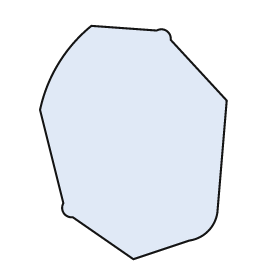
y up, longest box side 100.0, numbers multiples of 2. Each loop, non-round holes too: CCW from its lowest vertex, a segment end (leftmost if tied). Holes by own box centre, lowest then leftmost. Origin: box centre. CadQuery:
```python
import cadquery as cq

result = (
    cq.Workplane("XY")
    .moveTo(0.0, -50.0)
    .lineTo(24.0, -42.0)
    .threePointArc((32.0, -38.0), (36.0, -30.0))
    .lineTo(40.0, 18.0)
    .lineTo(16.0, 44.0)
    .threePointArc((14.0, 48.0), (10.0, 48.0))
    .lineTo(-18.0, 50.0)
    .threePointArc((-32.0, 34.0), (-40.0, 14.0))
    .lineTo(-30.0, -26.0)
    .threePointArc((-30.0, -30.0), (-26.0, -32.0))
    .close()
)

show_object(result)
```